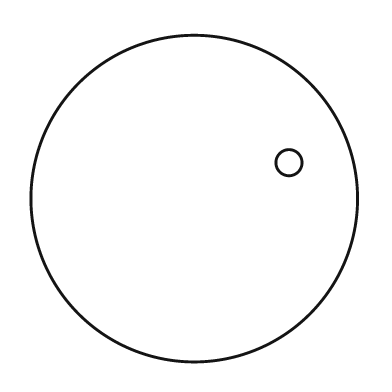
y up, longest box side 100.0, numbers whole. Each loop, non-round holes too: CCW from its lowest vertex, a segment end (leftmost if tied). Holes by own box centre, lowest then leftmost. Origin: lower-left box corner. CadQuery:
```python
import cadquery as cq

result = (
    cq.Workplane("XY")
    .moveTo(50.0, 50.0)
    .circle(50.0)
    .moveTo(79.0, 61.0)
    .circle(4.0)
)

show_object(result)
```